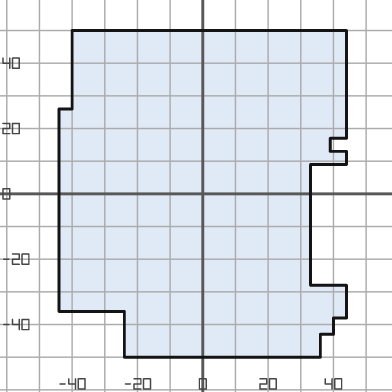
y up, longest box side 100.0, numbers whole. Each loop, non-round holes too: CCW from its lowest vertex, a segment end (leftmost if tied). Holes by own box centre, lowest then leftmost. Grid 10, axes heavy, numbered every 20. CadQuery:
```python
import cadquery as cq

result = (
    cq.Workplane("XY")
    .moveTo(-24.0, -50.0)
    .lineTo(36.0, -50.0)
    .lineTo(36.0, -43.0)
    .lineTo(40.0, -43.0)
    .lineTo(40.0, -38.0)
    .lineTo(44.0, -38.0)
    .lineTo(44.0, -28.0)
    .lineTo(33.0, -28.0)
    .lineTo(33.0, 9.0)
    .lineTo(44.0, 9.0)
    .lineTo(44.0, 13.0)
    .lineTo(39.0, 13.0)
    .lineTo(39.0, 17.0)
    .lineTo(44.0, 17.0)
    .lineTo(44.0, 50.0)
    .lineTo(-40.0, 50.0)
    .lineTo(-40.0, 26.0)
    .lineTo(-44.0, 26.0)
    .lineTo(-44.0, -36.0)
    .lineTo(-24.0, -36.0)
    .close()
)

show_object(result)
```